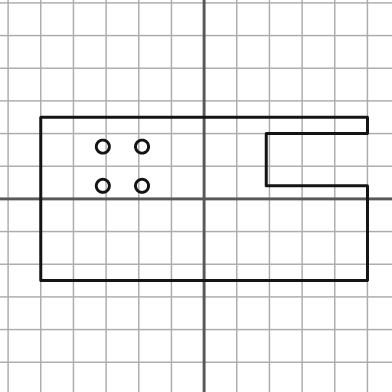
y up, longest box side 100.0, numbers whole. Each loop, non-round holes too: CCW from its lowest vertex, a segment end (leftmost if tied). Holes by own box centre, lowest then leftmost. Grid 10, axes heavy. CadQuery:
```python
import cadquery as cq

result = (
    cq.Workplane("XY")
    .moveTo(-50.0, -25.0)
    .lineTo(50.0, -25.0)
    .lineTo(50.0, 4.0)
    .lineTo(19.0, 4.0)
    .lineTo(19.0, 20.0)
    .lineTo(50.0, 20.0)
    .lineTo(50.0, 25.0)
    .lineTo(-50.0, 25.0)
    .close()
    .moveTo(-31.0, 4.0)
    .circle(2.0)
    .moveTo(-19.0, 4.0)
    .circle(2.0)
    .moveTo(-31.0, 16.0)
    .circle(2.0)
    .moveTo(-19.0, 16.0)
    .circle(2.0)
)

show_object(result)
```